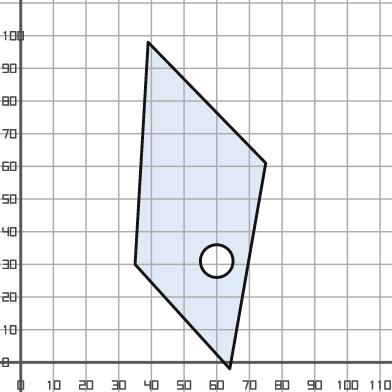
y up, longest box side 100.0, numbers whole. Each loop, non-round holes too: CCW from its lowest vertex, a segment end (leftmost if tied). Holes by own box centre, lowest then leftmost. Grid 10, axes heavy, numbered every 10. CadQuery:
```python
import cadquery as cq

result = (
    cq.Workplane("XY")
    .moveTo(64.0, -2.0)
    .lineTo(75.0, 61.0)
    .lineTo(39.0, 98.0)
    .lineTo(35.0, 30.0)
    .close()
    .moveTo(60.0, 31.0)
    .circle(5.0)
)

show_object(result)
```